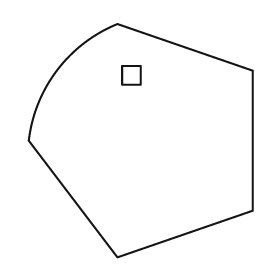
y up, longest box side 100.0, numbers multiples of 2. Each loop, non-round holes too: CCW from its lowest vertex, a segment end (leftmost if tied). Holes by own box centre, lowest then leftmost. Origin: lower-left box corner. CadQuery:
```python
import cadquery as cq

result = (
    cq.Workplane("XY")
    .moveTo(38.0, 0.0)
    .lineTo(96.0, 20.0)
    .lineTo(96.0, 80.0)
    .lineTo(38.0, 100.0)
    .threePointArc((12.0, 80.0), (0.0, 50.0))
    .close()
    .moveTo(40.0, 74.0)
    .lineTo(48.0, 74.0)
    .lineTo(48.0, 82.0)
    .lineTo(40.0, 82.0)
    .close()
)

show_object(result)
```